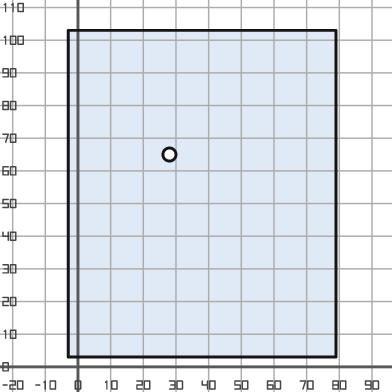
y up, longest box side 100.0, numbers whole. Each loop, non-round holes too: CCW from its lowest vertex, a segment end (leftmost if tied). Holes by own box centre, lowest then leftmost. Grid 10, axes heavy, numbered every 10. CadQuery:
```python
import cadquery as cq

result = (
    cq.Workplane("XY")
    .moveTo(-3.0, 3.0)
    .lineTo(79.0, 3.0)
    .lineTo(79.0, 103.0)
    .lineTo(-3.0, 103.0)
    .close()
    .moveTo(28.0, 65.0)
    .circle(2.0)
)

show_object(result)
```